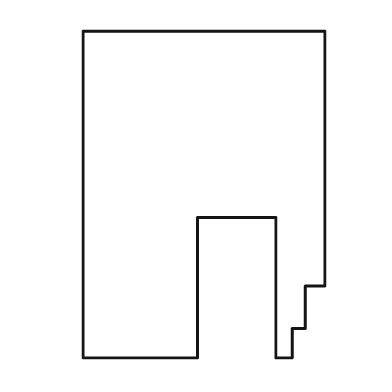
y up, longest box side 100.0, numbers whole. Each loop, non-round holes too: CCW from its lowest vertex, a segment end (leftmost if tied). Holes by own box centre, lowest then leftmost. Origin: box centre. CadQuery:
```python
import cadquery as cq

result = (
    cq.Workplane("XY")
    .moveTo(-37.0, -50.0)
    .lineTo(-2.0, -50.0)
    .lineTo(-2.0, -7.0)
    .lineTo(22.0, -7.0)
    .lineTo(22.0, -50.0)
    .lineTo(27.0, -50.0)
    .lineTo(27.0, -41.0)
    .lineTo(31.0, -41.0)
    .lineTo(31.0, -28.0)
    .lineTo(37.0, -28.0)
    .lineTo(37.0, 50.0)
    .lineTo(-37.0, 50.0)
    .close()
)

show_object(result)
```